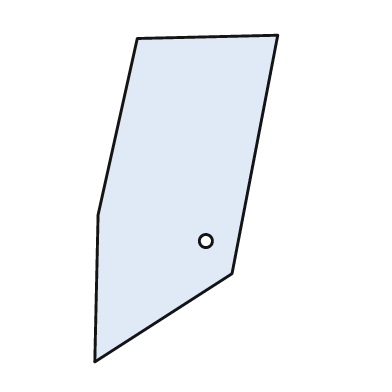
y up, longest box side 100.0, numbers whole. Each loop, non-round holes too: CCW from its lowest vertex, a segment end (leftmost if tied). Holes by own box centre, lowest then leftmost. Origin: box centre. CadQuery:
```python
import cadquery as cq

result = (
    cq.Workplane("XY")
    .moveTo(-28.0, -50.0)
    .lineTo(14.0, -23.0)
    .lineTo(28.0, 50.0)
    .lineTo(-15.0, 49.0)
    .lineTo(-27.0, -5.0)
    .close()
    .moveTo(6.0, -13.0)
    .circle(2.0)
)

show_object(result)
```